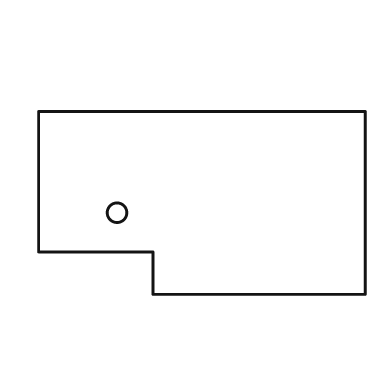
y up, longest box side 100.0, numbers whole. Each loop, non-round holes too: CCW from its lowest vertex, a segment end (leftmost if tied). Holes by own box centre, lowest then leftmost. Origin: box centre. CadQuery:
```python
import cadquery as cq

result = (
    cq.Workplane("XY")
    .moveTo(-15.0, -28.0)
    .lineTo(50.0, -28.0)
    .lineTo(50.0, 28.0)
    .lineTo(-50.0, 28.0)
    .lineTo(-50.0, -15.0)
    .lineTo(-15.0, -15.0)
    .close()
    .moveTo(-26.0, -3.0)
    .circle(3.0)
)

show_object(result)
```